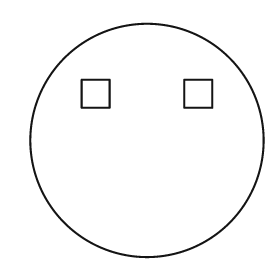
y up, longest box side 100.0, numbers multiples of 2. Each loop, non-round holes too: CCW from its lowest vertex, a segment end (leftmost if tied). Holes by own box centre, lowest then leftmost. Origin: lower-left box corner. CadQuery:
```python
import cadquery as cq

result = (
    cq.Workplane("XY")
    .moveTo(50.0, 50.0)
    .circle(50.0)
    .moveTo(22.0, 64.0)
    .lineTo(34.0, 64.0)
    .lineTo(34.0, 76.0)
    .lineTo(22.0, 76.0)
    .close()
    .moveTo(66.0, 64.0)
    .lineTo(78.0, 64.0)
    .lineTo(78.0, 76.0)
    .lineTo(66.0, 76.0)
    .close()
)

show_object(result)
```